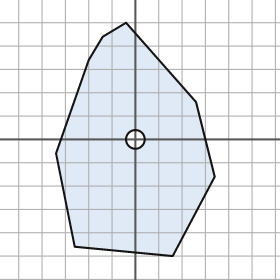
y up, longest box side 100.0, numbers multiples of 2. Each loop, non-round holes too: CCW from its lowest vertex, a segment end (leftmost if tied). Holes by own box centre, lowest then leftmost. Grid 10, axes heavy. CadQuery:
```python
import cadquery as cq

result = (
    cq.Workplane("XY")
    .moveTo(16.0, -50.0)
    .lineTo(34.0, -16.0)
    .lineTo(26.0, 16.0)
    .lineTo(-4.0, 50.0)
    .lineTo(-14.0, 44.0)
    .lineTo(-20.0, 34.0)
    .lineTo(-34.0, -6.0)
    .lineTo(-26.0, -46.0)
    .close()
    .moveTo(0.0, 0.0)
    .circle(4.0)
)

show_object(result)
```